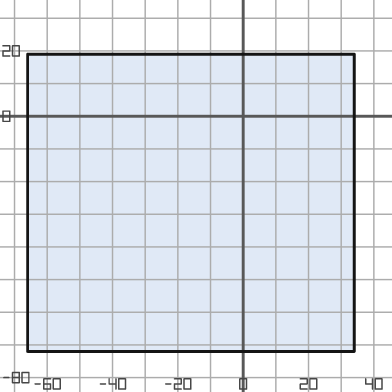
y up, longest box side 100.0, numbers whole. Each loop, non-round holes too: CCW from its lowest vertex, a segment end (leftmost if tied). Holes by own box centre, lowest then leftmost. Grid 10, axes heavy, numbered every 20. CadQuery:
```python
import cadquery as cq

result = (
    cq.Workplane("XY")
    .moveTo(-66.0, -72.0)
    .lineTo(34.0, -72.0)
    .lineTo(34.0, 19.0)
    .lineTo(-66.0, 19.0)
    .close()
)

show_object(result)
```